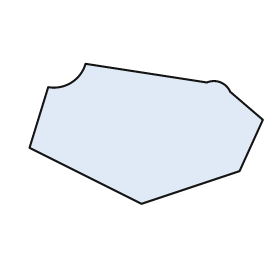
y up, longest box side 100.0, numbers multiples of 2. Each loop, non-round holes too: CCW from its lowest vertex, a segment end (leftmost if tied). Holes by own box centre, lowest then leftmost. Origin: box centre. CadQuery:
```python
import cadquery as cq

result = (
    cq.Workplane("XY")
    .moveTo(-2.0, -30.0)
    .lineTo(40.0, -16.0)
    .lineTo(50.0, 6.0)
    .lineTo(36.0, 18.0)
    .threePointArc((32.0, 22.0), (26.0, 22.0))
    .lineTo(-26.0, 30.0)
    .threePointArc((-32.0, 22.0), (-42.0, 20.0))
    .lineTo(-50.0, -6.0)
    .close()
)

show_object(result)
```